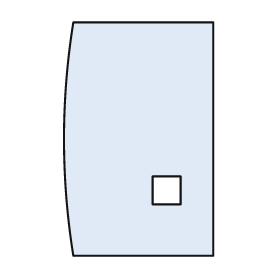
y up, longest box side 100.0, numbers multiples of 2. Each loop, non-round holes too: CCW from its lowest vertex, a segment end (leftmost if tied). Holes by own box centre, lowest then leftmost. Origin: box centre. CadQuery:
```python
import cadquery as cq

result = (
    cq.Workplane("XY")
    .moveTo(-28.0, -50.0)
    .lineTo(32.0, -50.0)
    .lineTo(32.0, 50.0)
    .lineTo(-28.0, 50.0)
    .threePointArc((-32.0, 0.0), (-28.0, -50.0))
    .close()
    .moveTo(6.0, -28.0)
    .lineTo(18.0, -28.0)
    .lineTo(18.0, -16.0)
    .lineTo(6.0, -16.0)
    .close()
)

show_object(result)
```